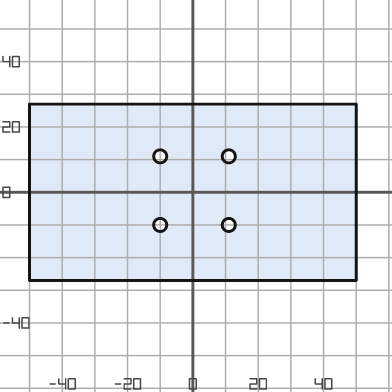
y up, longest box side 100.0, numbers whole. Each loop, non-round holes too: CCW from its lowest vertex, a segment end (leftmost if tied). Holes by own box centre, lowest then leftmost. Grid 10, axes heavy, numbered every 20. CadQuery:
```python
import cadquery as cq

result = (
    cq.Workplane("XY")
    .moveTo(-50.0, -27.0)
    .lineTo(50.0, -27.0)
    .lineTo(50.0, 27.0)
    .lineTo(-50.0, 27.0)
    .close()
    .moveTo(-10.0, -10.0)
    .circle(2.0)
    .moveTo(11.0, -10.0)
    .circle(2.0)
    .moveTo(-10.0, 11.0)
    .circle(2.0)
    .moveTo(11.0, 11.0)
    .circle(2.0)
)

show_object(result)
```